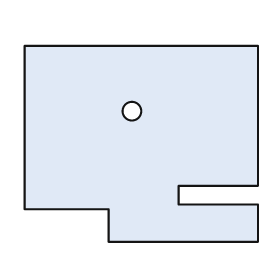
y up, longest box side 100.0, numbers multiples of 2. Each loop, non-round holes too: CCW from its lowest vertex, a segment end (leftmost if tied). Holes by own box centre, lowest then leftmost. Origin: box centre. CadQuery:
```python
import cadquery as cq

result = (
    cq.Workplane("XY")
    .moveTo(-14.0, -42.0)
    .lineTo(50.0, -42.0)
    .lineTo(50.0, -26.0)
    .lineTo(16.0, -26.0)
    .lineTo(16.0, -18.0)
    .lineTo(50.0, -18.0)
    .lineTo(50.0, 42.0)
    .lineTo(-50.0, 42.0)
    .lineTo(-50.0, -28.0)
    .lineTo(-14.0, -28.0)
    .close()
    .moveTo(-4.0, 14.0)
    .circle(4.0)
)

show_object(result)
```